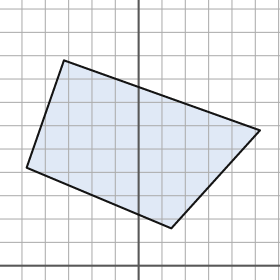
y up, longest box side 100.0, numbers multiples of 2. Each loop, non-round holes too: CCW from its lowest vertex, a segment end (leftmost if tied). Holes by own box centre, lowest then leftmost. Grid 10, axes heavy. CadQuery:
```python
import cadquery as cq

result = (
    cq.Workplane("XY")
    .moveTo(14.0, 16.0)
    .lineTo(52.0, 58.0)
    .lineTo(-32.0, 88.0)
    .lineTo(-48.0, 42.0)
    .close()
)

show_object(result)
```